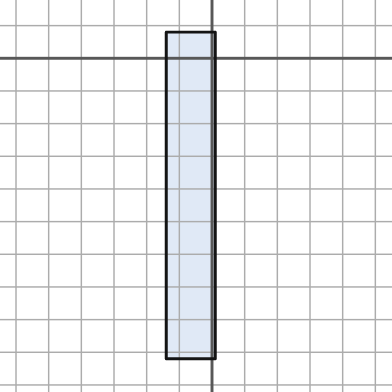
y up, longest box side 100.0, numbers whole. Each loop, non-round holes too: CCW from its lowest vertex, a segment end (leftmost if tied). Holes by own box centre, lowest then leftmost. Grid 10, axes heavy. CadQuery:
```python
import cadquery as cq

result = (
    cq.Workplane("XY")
    .moveTo(-14.0, -92.0)
    .lineTo(1.0, -92.0)
    .lineTo(1.0, 8.0)
    .lineTo(-14.0, 8.0)
    .close()
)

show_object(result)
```